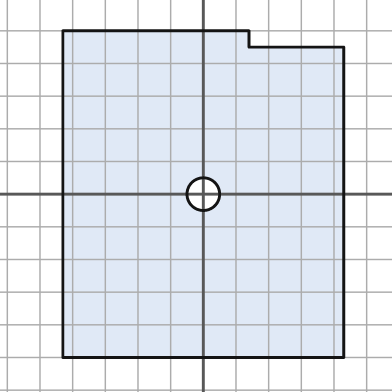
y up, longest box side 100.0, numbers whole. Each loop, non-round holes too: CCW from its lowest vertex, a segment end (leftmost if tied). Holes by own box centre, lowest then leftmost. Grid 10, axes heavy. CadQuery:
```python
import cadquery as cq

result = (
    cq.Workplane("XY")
    .moveTo(-43.0, -50.0)
    .lineTo(43.0, -50.0)
    .lineTo(43.0, 45.0)
    .lineTo(14.0, 45.0)
    .lineTo(14.0, 50.0)
    .lineTo(-43.0, 50.0)
    .close()
    .moveTo(0.0, 0.0)
    .circle(5.0)
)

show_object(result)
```